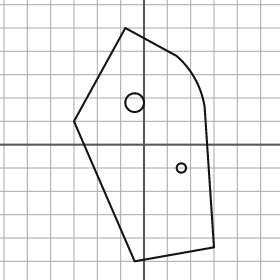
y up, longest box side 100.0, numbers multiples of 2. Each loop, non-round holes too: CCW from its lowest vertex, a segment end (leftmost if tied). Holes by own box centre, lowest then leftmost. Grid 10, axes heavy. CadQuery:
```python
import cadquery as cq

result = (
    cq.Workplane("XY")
    .moveTo(-4.0, -50.0)
    .lineTo(30.0, -44.0)
    .lineTo(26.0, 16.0)
    .threePointArc((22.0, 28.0), (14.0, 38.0))
    .lineTo(-8.0, 50.0)
    .lineTo(-30.0, 10.0)
    .close()
    .moveTo(16.0, -10.0)
    .circle(2.0)
    .moveTo(-4.0, 18.0)
    .circle(4.0)
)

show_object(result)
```